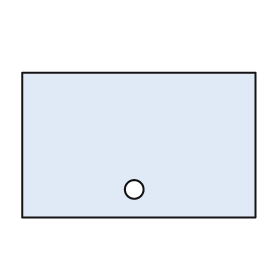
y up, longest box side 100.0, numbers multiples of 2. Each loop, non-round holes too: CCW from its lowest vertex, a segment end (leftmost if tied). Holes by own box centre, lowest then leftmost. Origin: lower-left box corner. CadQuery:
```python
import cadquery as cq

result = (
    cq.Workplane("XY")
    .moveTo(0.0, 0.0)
    .lineTo(100.0, 0.0)
    .lineTo(100.0, 62.0)
    .lineTo(0.0, 62.0)
    .close()
    .moveTo(48.0, 12.0)
    .circle(4.0)
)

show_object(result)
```